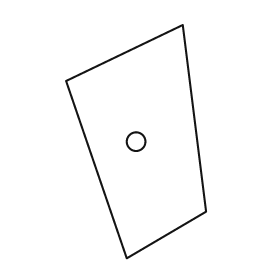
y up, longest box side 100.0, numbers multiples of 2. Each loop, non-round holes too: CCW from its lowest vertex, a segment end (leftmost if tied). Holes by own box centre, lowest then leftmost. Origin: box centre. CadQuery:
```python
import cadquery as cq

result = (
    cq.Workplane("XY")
    .moveTo(-4.0, -50.0)
    .lineTo(30.0, -30.0)
    .lineTo(20.0, 50.0)
    .lineTo(-30.0, 26.0)
    .close()
    .moveTo(0.0, 0.0)
    .circle(4.0)
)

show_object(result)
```